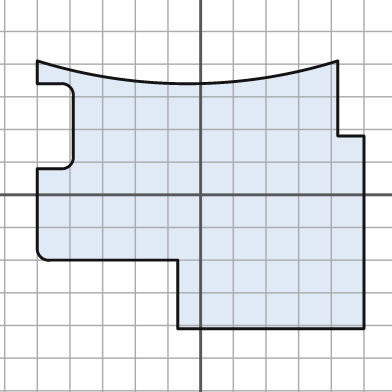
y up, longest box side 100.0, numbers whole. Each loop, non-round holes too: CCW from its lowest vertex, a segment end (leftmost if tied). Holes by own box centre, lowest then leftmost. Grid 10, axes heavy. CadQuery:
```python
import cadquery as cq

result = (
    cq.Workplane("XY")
    .moveTo(-7.0, -41.0)
    .lineTo(50.0, -41.0)
    .lineTo(50.0, 18.0)
    .lineTo(42.0, 18.0)
    .lineTo(42.0, 41.0)
    .threePointArc((-4.0, 34.0), (-50.0, 41.0))
    .lineTo(-50.0, 34.0)
    .lineTo(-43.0, 34.0)
    .threePointArc((-40.0, 33.0), (-39.0, 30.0))
    .lineTo(-39.0, 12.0)
    .threePointArc((-40.0, 9.0), (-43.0, 8.0))
    .lineTo(-50.0, 8.0)
    .lineTo(-50.0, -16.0)
    .threePointArc((-49.0, -19.0), (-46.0, -20.0))
    .lineTo(-7.0, -20.0)
    .close()
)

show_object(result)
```